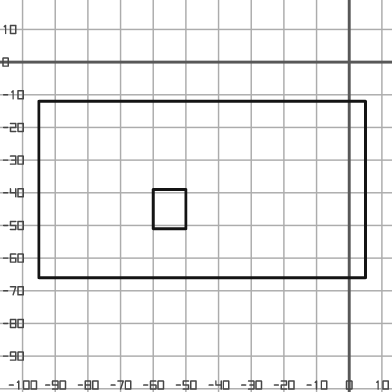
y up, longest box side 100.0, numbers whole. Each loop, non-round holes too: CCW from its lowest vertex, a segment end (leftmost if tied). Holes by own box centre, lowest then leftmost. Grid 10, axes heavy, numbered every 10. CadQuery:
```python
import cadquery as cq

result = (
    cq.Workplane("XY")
    .moveTo(-95.0, -66.0)
    .lineTo(5.0, -66.0)
    .lineTo(5.0, -12.0)
    .lineTo(-95.0, -12.0)
    .close()
    .moveTo(-60.0, -51.0)
    .lineTo(-50.0, -51.0)
    .lineTo(-50.0, -39.0)
    .lineTo(-60.0, -39.0)
    .close()
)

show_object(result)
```